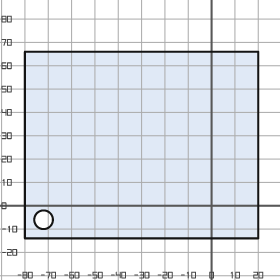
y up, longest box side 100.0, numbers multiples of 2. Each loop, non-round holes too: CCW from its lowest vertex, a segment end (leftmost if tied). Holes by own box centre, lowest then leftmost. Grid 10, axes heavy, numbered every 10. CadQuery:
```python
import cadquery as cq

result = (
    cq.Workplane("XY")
    .moveTo(-80.0, -14.0)
    .lineTo(20.0, -14.0)
    .lineTo(20.0, 66.0)
    .lineTo(-80.0, 66.0)
    .close()
    .moveTo(-72.0, -6.0)
    .circle(4.0)
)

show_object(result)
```